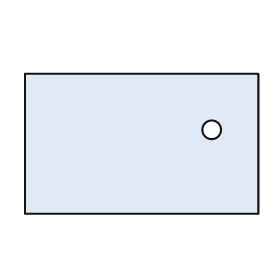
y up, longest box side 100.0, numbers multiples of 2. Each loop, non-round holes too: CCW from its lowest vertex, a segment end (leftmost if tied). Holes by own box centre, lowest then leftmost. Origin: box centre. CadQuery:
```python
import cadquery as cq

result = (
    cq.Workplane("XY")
    .moveTo(-50.0, -30.0)
    .lineTo(50.0, -30.0)
    .lineTo(50.0, 30.0)
    .lineTo(-50.0, 30.0)
    .close()
    .moveTo(30.0, 6.0)
    .circle(4.0)
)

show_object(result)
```